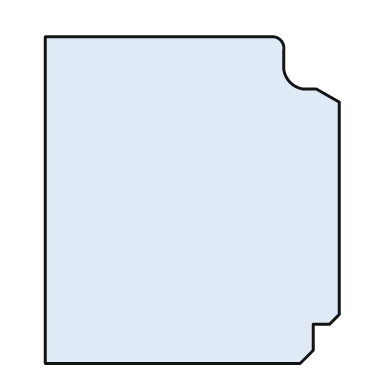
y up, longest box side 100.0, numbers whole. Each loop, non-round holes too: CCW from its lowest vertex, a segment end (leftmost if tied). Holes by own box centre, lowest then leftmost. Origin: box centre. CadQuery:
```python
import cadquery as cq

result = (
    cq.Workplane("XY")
    .moveTo(-45.0, -50.0)
    .lineTo(33.0, -50.0)
    .lineTo(37.0, -46.0)
    .lineTo(37.0, -38.0)
    .lineTo(42.0, -38.0)
    .lineTo(45.0, -35.0)
    .lineTo(45.0, 30.0)
    .lineTo(38.0, 34.0)
    .lineTo(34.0, 34.0)
    .threePointArc((30.0, 36.0), (28.0, 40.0))
    .lineTo(28.0, 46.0)
    .threePointArc((27.0, 49.0), (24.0, 50.0))
    .lineTo(-45.0, 50.0)
    .close()
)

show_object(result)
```